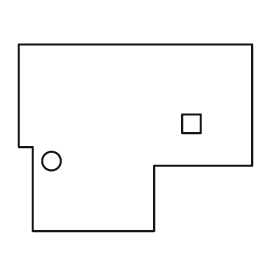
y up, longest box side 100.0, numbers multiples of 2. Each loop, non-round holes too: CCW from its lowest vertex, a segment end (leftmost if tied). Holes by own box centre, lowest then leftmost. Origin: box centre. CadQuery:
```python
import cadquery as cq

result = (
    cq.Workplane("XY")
    .moveTo(-44.0, -40.0)
    .lineTo(8.0, -40.0)
    .lineTo(8.0, -12.0)
    .lineTo(50.0, -12.0)
    .lineTo(50.0, 40.0)
    .lineTo(-50.0, 40.0)
    .lineTo(-50.0, -4.0)
    .lineTo(-44.0, -4.0)
    .close()
    .moveTo(-36.0, -10.0)
    .circle(4.0)
    .moveTo(20.0, 2.0)
    .lineTo(28.0, 2.0)
    .lineTo(28.0, 10.0)
    .lineTo(20.0, 10.0)
    .close()
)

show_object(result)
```